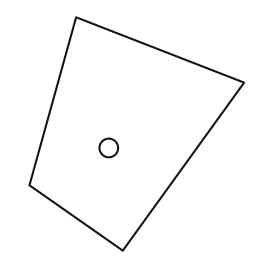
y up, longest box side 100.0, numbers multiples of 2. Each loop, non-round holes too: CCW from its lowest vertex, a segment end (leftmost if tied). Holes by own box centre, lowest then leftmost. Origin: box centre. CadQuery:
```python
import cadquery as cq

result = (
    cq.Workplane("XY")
    .moveTo(-6.0, -50.0)
    .lineTo(46.0, 22.0)
    .lineTo(-26.0, 50.0)
    .lineTo(-46.0, -22.0)
    .close()
    .moveTo(-12.0, -6.0)
    .circle(4.0)
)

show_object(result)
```